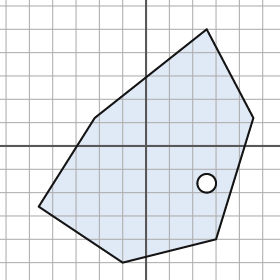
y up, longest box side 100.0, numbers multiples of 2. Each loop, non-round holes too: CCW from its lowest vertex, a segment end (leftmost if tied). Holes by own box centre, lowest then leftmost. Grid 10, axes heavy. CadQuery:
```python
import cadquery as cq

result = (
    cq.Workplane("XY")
    .moveTo(-10.0, -50.0)
    .lineTo(30.0, -40.0)
    .lineTo(46.0, 12.0)
    .lineTo(26.0, 50.0)
    .lineTo(-22.0, 12.0)
    .lineTo(-46.0, -26.0)
    .close()
    .moveTo(26.0, -16.0)
    .circle(4.0)
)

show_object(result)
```